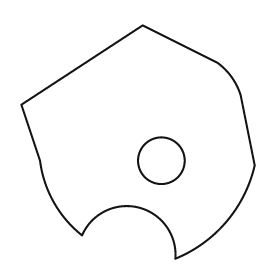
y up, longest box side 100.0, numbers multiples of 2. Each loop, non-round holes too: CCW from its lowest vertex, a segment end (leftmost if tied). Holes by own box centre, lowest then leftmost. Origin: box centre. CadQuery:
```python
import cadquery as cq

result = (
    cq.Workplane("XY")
    .moveTo(16.0, -50.0)
    .threePointArc((38.0, -34.0), (50.0, -10.0))
    .lineTo(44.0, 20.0)
    .threePointArc((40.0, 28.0), (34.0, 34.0))
    .lineTo(2.0, 50.0)
    .lineTo(-50.0, 16.0)
    .lineTo(-42.0, -8.0)
    .threePointArc((-36.0, -26.0), (-24.0, -40.0))
    .threePointArc((0.0, -28.0), (16.0, -50.0))
    .close()
    .moveTo(10.0, -8.0)
    .circle(10.0)
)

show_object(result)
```